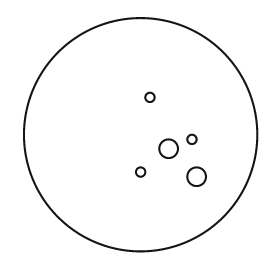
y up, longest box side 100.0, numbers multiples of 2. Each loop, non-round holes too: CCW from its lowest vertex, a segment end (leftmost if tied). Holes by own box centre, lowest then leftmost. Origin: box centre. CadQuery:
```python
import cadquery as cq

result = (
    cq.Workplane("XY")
    .moveTo(0.0, 0.0)
    .circle(50.0)
    .moveTo(24.0, -18.0)
    .circle(4.0)
    .moveTo(0.0, -16.0)
    .circle(2.0)
    .moveTo(12.0, -6.0)
    .circle(4.0)
    .moveTo(22.0, -2.0)
    .circle(2.0)
    .moveTo(4.0, 16.0)
    .circle(2.0)
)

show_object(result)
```